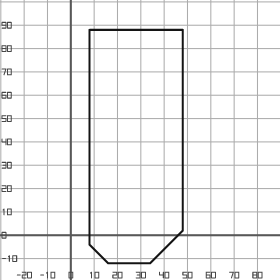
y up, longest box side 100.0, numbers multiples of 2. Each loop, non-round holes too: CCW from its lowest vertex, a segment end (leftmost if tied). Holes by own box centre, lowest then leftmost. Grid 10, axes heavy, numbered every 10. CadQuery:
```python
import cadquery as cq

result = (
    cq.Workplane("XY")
    .moveTo(16.0, -12.0)
    .lineTo(34.0, -12.0)
    .lineTo(48.0, 2.0)
    .lineTo(48.0, 88.0)
    .lineTo(8.0, 88.0)
    .lineTo(8.0, -4.0)
    .close()
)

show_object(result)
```